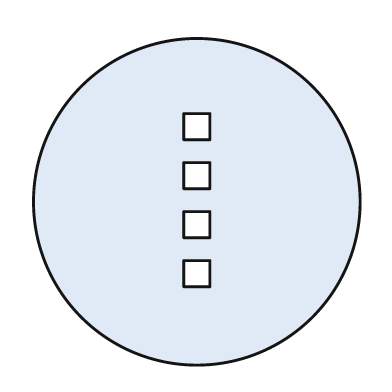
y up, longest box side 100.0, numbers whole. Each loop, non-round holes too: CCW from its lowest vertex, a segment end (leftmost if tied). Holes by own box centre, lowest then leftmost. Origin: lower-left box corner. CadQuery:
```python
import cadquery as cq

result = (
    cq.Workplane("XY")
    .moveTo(50.0, 50.0)
    .circle(50.0)
    .moveTo(46.0, 24.0)
    .lineTo(54.0, 24.0)
    .lineTo(54.0, 32.0)
    .lineTo(46.0, 32.0)
    .close()
    .moveTo(46.0, 39.0)
    .lineTo(54.0, 39.0)
    .lineTo(54.0, 47.0)
    .lineTo(46.0, 47.0)
    .close()
    .moveTo(46.0, 54.0)
    .lineTo(54.0, 54.0)
    .lineTo(54.0, 62.0)
    .lineTo(46.0, 62.0)
    .close()
    .moveTo(46.0, 69.0)
    .lineTo(54.0, 69.0)
    .lineTo(54.0, 77.0)
    .lineTo(46.0, 77.0)
    .close()
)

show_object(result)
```